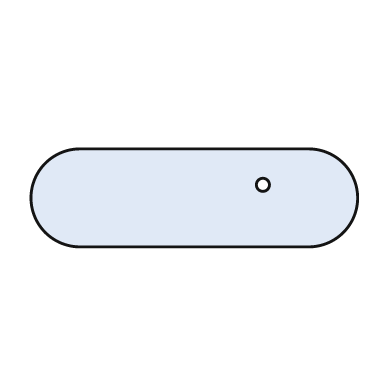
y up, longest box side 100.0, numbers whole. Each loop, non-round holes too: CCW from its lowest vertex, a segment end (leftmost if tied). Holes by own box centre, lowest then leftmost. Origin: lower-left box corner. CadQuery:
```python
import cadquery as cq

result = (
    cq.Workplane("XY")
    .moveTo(15.0, 0.0)
    .lineTo(85.0, 0.0)
    .threePointArc((100.0, 15.0), (85.0, 30.0))
    .lineTo(15.0, 30.0)
    .threePointArc((0.0, 15.0), (15.0, 0.0))
    .close()
    .moveTo(71.0, 19.0)
    .circle(2.0)
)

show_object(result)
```